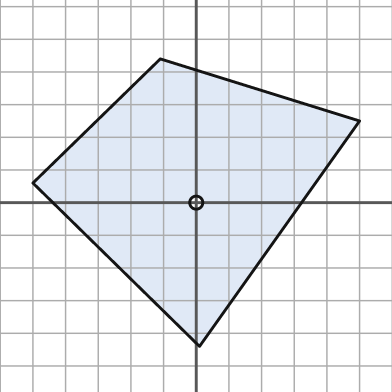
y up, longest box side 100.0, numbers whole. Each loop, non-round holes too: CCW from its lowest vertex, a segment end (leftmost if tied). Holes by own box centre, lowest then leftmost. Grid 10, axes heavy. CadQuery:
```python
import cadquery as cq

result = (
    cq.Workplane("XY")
    .moveTo(1.0, -44.0)
    .lineTo(50.0, 25.0)
    .lineTo(-11.0, 44.0)
    .lineTo(-50.0, 6.0)
    .close()
    .moveTo(0.0, 0.0)
    .circle(2.0)
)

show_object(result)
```